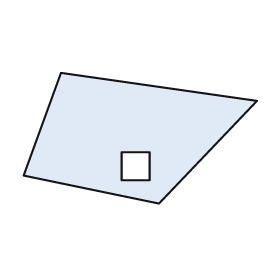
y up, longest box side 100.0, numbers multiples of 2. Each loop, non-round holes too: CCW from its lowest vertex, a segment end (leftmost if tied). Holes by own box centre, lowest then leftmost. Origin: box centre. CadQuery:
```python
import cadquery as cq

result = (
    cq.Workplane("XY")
    .moveTo(8.0, -28.0)
    .lineTo(50.0, 16.0)
    .lineTo(-34.0, 28.0)
    .lineTo(-50.0, -16.0)
    .close()
    .moveTo(-8.0, -18.0)
    .lineTo(4.0, -18.0)
    .lineTo(4.0, -6.0)
    .lineTo(-8.0, -6.0)
    .close()
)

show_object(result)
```